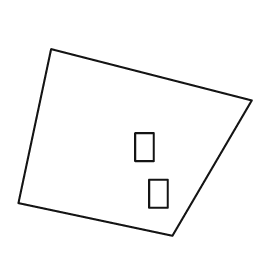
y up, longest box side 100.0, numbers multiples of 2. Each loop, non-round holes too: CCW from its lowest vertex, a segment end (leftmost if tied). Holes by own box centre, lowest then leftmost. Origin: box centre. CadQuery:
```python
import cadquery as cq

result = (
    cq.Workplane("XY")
    .moveTo(16.0, -40.0)
    .lineTo(50.0, 18.0)
    .lineTo(-36.0, 40.0)
    .lineTo(-50.0, -26.0)
    .close()
    .moveTo(6.0, -28.0)
    .lineTo(14.0, -28.0)
    .lineTo(14.0, -16.0)
    .lineTo(6.0, -16.0)
    .close()
    .moveTo(0.0, -8.0)
    .lineTo(8.0, -8.0)
    .lineTo(8.0, 4.0)
    .lineTo(0.0, 4.0)
    .close()
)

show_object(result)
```